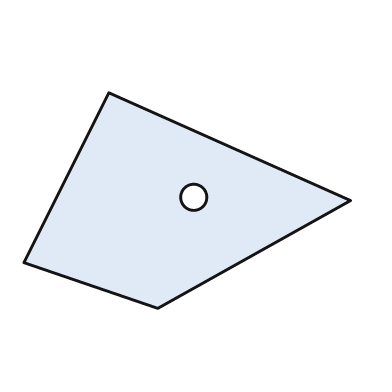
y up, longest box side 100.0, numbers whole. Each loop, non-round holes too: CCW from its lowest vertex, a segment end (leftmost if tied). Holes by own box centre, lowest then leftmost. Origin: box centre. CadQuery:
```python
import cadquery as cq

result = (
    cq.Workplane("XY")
    .moveTo(-9.0, -33.0)
    .lineTo(50.0, 0.0)
    .lineTo(-24.0, 33.0)
    .lineTo(-50.0, -19.0)
    .close()
    .moveTo(2.0, 1.0)
    .circle(4.0)
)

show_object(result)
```